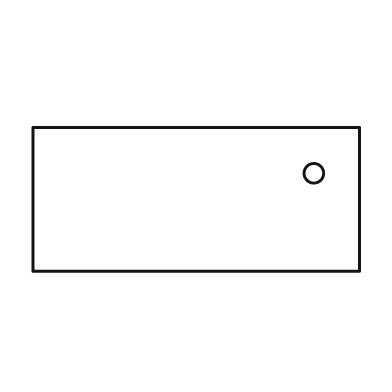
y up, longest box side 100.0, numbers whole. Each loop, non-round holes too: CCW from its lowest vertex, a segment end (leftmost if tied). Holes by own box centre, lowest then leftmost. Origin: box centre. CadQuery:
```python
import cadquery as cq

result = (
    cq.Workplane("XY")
    .moveTo(-50.0, -22.0)
    .lineTo(50.0, -22.0)
    .lineTo(50.0, 22.0)
    .lineTo(-50.0, 22.0)
    .close()
    .moveTo(36.0, 8.0)
    .circle(3.0)
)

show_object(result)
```